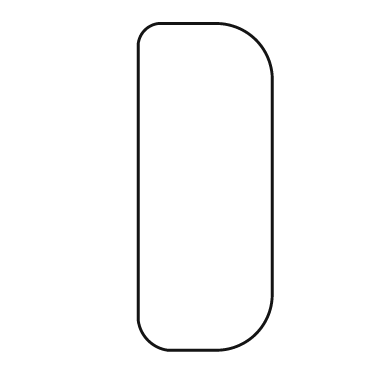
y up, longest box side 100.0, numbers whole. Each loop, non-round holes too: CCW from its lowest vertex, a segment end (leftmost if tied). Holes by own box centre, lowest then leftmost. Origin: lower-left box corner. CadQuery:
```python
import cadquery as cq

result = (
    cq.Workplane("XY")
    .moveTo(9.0, 0.0)
    .lineTo(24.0, 0.0)
    .threePointArc((36.0, 5.0), (41.0, 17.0))
    .lineTo(41.0, 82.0)
    .threePointArc((36.0, 95.0), (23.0, 100.0))
    .lineTo(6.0, 100.0)
    .threePointArc((2.0, 98.0), (0.0, 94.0))
    .lineTo(0.0, 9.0)
    .threePointArc((3.0, 3.0), (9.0, 0.0))
    .close()
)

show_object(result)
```